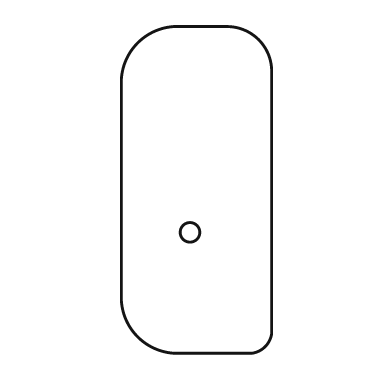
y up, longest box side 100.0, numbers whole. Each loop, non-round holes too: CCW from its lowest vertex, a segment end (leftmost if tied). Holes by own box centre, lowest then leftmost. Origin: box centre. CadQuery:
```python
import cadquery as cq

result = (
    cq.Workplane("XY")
    .moveTo(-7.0, -50.0)
    .lineTo(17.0, -50.0)
    .threePointArc((21.0, -48.0), (23.0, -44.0))
    .lineTo(23.0, 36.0)
    .threePointArc((19.0, 46.0), (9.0, 50.0))
    .lineTo(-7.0, 50.0)
    .threePointArc((-18.0, 45.0), (-23.0, 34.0))
    .lineTo(-23.0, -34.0)
    .threePointArc((-18.0, -45.0), (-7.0, -50.0))
    .close()
    .moveTo(-2.0, -13.0)
    .circle(3.0)
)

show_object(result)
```